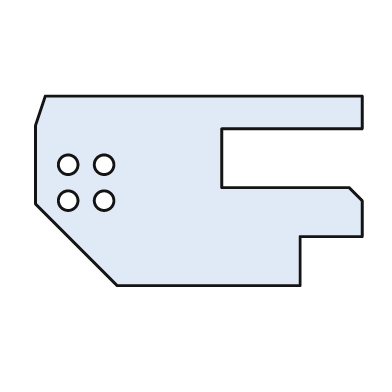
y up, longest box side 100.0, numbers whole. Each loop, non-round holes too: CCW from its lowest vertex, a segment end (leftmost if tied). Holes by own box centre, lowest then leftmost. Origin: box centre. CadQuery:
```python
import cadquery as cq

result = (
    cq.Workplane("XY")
    .moveTo(-25.0, -29.0)
    .lineTo(31.0, -29.0)
    .lineTo(31.0, -14.0)
    .lineTo(50.0, -14.0)
    .lineTo(50.0, -3.0)
    .lineTo(46.0, 1.0)
    .lineTo(7.0, 1.0)
    .lineTo(7.0, 19.0)
    .lineTo(50.0, 19.0)
    .lineTo(50.0, 29.0)
    .lineTo(-47.0, 29.0)
    .lineTo(-50.0, 20.0)
    .lineTo(-50.0, -4.0)
    .close()
    .moveTo(-40.0, -3.0)
    .circle(3.0)
    .moveTo(-29.0, -3.0)
    .circle(3.0)
    .moveTo(-40.0, 8.0)
    .circle(3.0)
    .moveTo(-29.0, 8.0)
    .circle(3.0)
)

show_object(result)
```